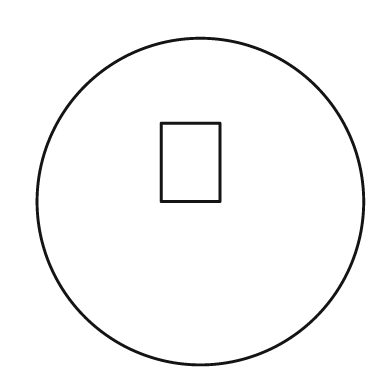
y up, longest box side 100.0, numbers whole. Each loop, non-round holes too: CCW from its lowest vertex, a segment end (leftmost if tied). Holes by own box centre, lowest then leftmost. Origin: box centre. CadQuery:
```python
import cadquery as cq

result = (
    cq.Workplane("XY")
    .moveTo(0.0, 0.0)
    .circle(50.0)
    .moveTo(-12.0, 0.0)
    .lineTo(6.0, 0.0)
    .lineTo(6.0, 24.0)
    .lineTo(-12.0, 24.0)
    .close()
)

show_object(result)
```